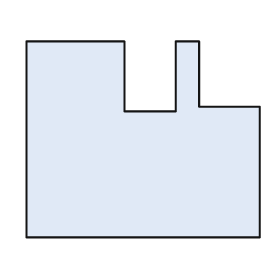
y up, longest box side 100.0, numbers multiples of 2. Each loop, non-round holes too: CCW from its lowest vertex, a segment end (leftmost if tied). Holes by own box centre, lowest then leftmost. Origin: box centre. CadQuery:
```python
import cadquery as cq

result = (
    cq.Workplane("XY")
    .moveTo(-50.0, -42.0)
    .lineTo(50.0, -42.0)
    .lineTo(50.0, 14.0)
    .lineTo(24.0, 14.0)
    .lineTo(24.0, 42.0)
    .lineTo(14.0, 42.0)
    .lineTo(14.0, 12.0)
    .lineTo(-8.0, 12.0)
    .lineTo(-8.0, 42.0)
    .lineTo(-50.0, 42.0)
    .close()
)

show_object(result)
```